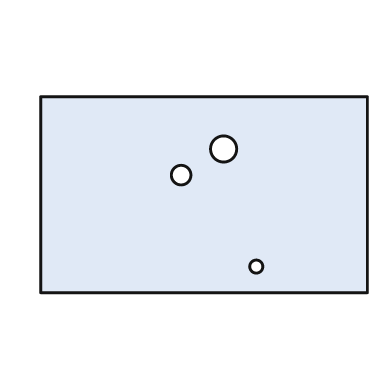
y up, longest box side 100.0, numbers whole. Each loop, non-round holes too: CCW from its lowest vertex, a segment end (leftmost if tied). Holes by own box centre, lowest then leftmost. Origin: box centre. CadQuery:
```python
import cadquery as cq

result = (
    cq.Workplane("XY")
    .moveTo(-50.0, -30.0)
    .lineTo(50.0, -30.0)
    .lineTo(50.0, 30.0)
    .lineTo(-50.0, 30.0)
    .close()
    .moveTo(16.0, -22.0)
    .circle(2.0)
    .moveTo(-7.0, 6.0)
    .circle(3.0)
    .moveTo(6.0, 14.0)
    .circle(4.0)
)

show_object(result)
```